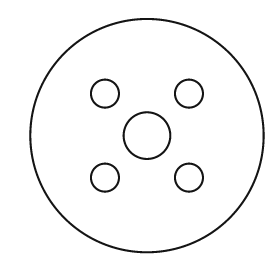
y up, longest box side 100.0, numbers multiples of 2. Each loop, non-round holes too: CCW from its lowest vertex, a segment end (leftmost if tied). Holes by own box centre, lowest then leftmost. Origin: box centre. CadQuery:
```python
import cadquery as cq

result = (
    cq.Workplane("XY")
    .moveTo(0.0, 0.0)
    .circle(50.0)
    .moveTo(-18.0, -18.0)
    .circle(6.0)
    .moveTo(18.0, -18.0)
    .circle(6.0)
    .moveTo(0.0, 0.0)
    .circle(10.0)
    .moveTo(-18.0, 18.0)
    .circle(6.0)
    .moveTo(18.0, 18.0)
    .circle(6.0)
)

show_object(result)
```